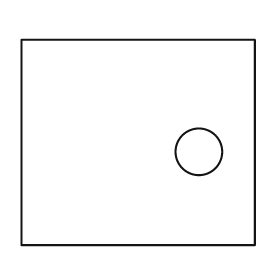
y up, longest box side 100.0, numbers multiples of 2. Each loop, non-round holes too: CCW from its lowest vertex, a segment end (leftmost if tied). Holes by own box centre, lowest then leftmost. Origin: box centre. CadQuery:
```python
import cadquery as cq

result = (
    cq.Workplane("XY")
    .moveTo(-50.0, -44.0)
    .lineTo(50.0, -44.0)
    .lineTo(50.0, 44.0)
    .lineTo(-50.0, 44.0)
    .close()
    .moveTo(26.0, -4.0)
    .circle(10.0)
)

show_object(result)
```